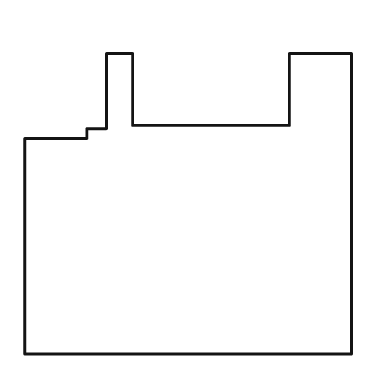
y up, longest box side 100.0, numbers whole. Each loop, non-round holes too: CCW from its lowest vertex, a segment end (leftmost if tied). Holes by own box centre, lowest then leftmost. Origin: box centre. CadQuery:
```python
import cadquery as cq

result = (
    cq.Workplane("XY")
    .moveTo(-50.0, -46.0)
    .lineTo(50.0, -46.0)
    .lineTo(50.0, 46.0)
    .lineTo(31.0, 46.0)
    .lineTo(31.0, 24.0)
    .lineTo(-17.0, 24.0)
    .lineTo(-17.0, 46.0)
    .lineTo(-25.0, 46.0)
    .lineTo(-25.0, 23.0)
    .lineTo(-31.0, 23.0)
    .lineTo(-31.0, 20.0)
    .lineTo(-50.0, 20.0)
    .close()
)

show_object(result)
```